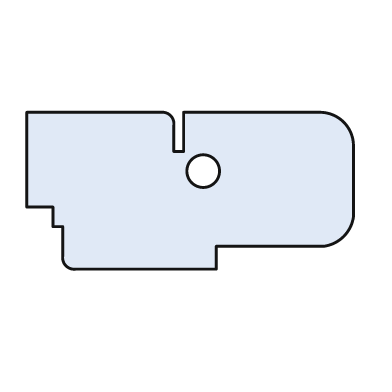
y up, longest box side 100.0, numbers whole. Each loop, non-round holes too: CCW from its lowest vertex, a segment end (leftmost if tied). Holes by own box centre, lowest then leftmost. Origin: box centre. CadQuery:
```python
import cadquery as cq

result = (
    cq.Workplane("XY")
    .moveTo(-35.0, -24.0)
    .lineTo(8.0, -24.0)
    .lineTo(8.0, -17.0)
    .lineTo(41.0, -17.0)
    .threePointArc((47.0, -14.0), (50.0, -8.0))
    .lineTo(50.0, 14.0)
    .threePointArc((47.0, 21.0), (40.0, 24.0))
    .lineTo(-2.0, 24.0)
    .lineTo(-2.0, 12.0)
    .lineTo(-5.0, 12.0)
    .lineTo(-5.0, 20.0)
    .threePointArc((-6.0, 23.0), (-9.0, 24.0))
    .lineTo(-50.0, 24.0)
    .lineTo(-50.0, -5.0)
    .lineTo(-42.0, -5.0)
    .lineTo(-42.0, -11.0)
    .lineTo(-39.0, -11.0)
    .lineTo(-39.0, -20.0)
    .threePointArc((-38.0, -23.0), (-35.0, -24.0))
    .close()
    .moveTo(4.0, 6.0)
    .circle(5.0)
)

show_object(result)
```